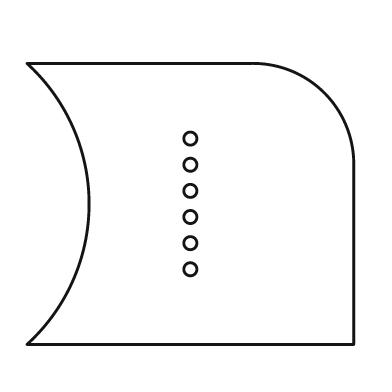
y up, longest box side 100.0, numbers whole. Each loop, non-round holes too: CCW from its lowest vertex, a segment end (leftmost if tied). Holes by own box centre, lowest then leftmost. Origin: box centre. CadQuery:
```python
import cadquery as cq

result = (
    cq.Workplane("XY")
    .moveTo(-50.0, -43.0)
    .lineTo(50.0, -43.0)
    .lineTo(50.0, 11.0)
    .threePointArc((41.0, 34.0), (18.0, 43.0))
    .lineTo(-50.0, 43.0)
    .threePointArc((-31.0, 0.0), (-50.0, -43.0))
    .close()
    .moveTo(0.0, -20.0)
    .circle(2.0)
    .moveTo(0.0, -12.0)
    .circle(2.0)
    .moveTo(0.0, -4.0)
    .circle(2.0)
    .moveTo(0.0, 4.0)
    .circle(2.0)
    .moveTo(0.0, 12.0)
    .circle(2.0)
    .moveTo(0.0, 20.0)
    .circle(2.0)
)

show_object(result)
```